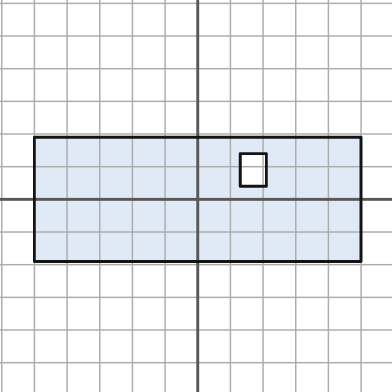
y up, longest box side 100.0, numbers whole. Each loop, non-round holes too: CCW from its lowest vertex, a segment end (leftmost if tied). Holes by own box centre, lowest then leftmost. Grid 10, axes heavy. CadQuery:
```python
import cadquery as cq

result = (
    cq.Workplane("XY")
    .moveTo(-50.0, -19.0)
    .lineTo(50.0, -19.0)
    .lineTo(50.0, 19.0)
    .lineTo(-50.0, 19.0)
    .close()
    .moveTo(13.0, 4.0)
    .lineTo(21.0, 4.0)
    .lineTo(21.0, 14.0)
    .lineTo(13.0, 14.0)
    .close()
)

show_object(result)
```